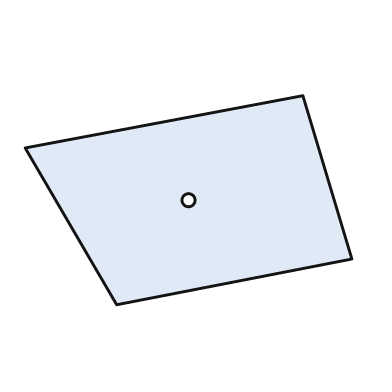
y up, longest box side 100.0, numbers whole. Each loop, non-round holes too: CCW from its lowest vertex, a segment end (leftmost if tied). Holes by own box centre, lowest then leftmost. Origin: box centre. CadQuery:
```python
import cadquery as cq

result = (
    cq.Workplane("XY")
    .moveTo(-22.0, -32.0)
    .lineTo(50.0, -18.0)
    .lineTo(35.0, 32.0)
    .lineTo(-50.0, 16.0)
    .close()
    .moveTo(0.0, 0.0)
    .circle(2.0)
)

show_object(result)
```